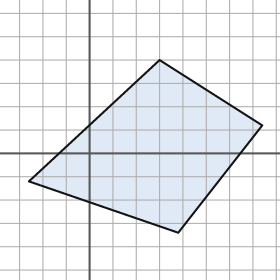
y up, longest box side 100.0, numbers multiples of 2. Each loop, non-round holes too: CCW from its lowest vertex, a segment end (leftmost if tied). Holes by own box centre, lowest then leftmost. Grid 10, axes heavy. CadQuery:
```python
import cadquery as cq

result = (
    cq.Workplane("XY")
    .moveTo(38.0, -34.0)
    .lineTo(74.0, 12.0)
    .lineTo(30.0, 40.0)
    .lineTo(-26.0, -12.0)
    .close()
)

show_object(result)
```